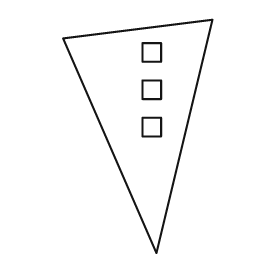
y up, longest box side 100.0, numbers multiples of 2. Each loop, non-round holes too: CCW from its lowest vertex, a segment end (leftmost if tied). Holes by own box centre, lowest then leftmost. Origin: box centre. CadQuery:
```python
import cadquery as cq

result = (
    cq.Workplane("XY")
    .moveTo(8.0, -50.0)
    .lineTo(32.0, 50.0)
    .lineTo(-32.0, 42.0)
    .close()
    .moveTo(2.0, 0.0)
    .lineTo(10.0, 0.0)
    .lineTo(10.0, 8.0)
    .lineTo(2.0, 8.0)
    .close()
    .moveTo(2.0, 16.0)
    .lineTo(10.0, 16.0)
    .lineTo(10.0, 24.0)
    .lineTo(2.0, 24.0)
    .close()
    .moveTo(2.0, 32.0)
    .lineTo(10.0, 32.0)
    .lineTo(10.0, 40.0)
    .lineTo(2.0, 40.0)
    .close()
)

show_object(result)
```